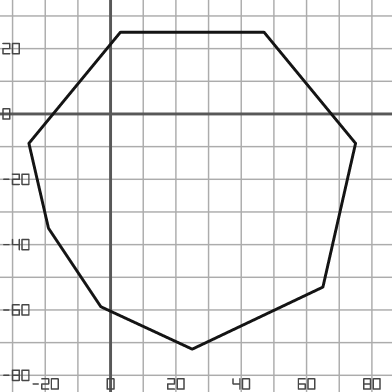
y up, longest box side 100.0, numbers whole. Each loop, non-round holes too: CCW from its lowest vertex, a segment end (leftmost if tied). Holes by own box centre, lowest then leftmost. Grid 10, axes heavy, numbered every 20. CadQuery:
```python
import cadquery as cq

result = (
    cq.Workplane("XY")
    .moveTo(25.0, -72.0)
    .lineTo(65.0, -53.0)
    .lineTo(75.0, -9.0)
    .lineTo(47.0, 25.0)
    .lineTo(3.0, 25.0)
    .lineTo(-25.0, -9.0)
    .lineTo(-19.0, -35.0)
    .lineTo(-3.0, -59.0)
    .close()
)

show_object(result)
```